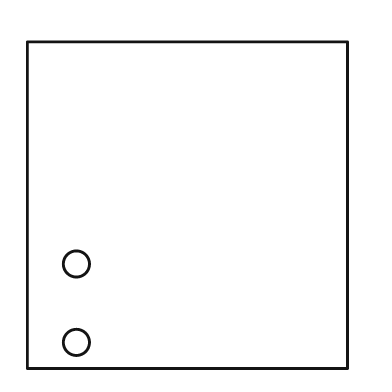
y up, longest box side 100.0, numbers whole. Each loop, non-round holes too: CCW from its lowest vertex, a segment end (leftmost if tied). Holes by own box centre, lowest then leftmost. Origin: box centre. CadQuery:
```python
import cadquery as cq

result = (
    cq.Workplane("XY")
    .moveTo(-49.0, -50.0)
    .lineTo(49.0, -50.0)
    .lineTo(49.0, 50.0)
    .lineTo(-49.0, 50.0)
    .close()
    .moveTo(-34.0, -42.0)
    .circle(4.0)
    .moveTo(-34.0, -18.0)
    .circle(4.0)
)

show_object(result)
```